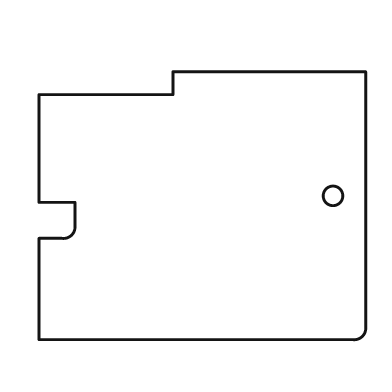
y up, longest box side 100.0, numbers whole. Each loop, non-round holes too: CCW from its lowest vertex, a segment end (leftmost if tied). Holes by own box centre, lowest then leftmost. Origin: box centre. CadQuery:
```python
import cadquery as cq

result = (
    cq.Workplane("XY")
    .moveTo(-50.0, -41.0)
    .lineTo(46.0, -41.0)
    .threePointArc((49.0, -40.0), (50.0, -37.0))
    .lineTo(50.0, 41.0)
    .lineTo(-9.0, 41.0)
    .lineTo(-9.0, 34.0)
    .lineTo(-50.0, 34.0)
    .lineTo(-50.0, 1.0)
    .lineTo(-39.0, 1.0)
    .lineTo(-39.0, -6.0)
    .threePointArc((-40.0, -9.0), (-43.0, -10.0))
    .lineTo(-50.0, -10.0)
    .close()
    .moveTo(40.0, 3.0)
    .circle(3.0)
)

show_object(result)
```